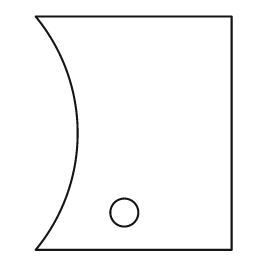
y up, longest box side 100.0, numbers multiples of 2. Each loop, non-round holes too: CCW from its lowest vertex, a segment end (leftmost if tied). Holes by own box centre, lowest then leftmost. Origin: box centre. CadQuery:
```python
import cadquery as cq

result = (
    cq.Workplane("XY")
    .moveTo(-42.0, -50.0)
    .lineTo(42.0, -50.0)
    .lineTo(42.0, 50.0)
    .lineTo(-42.0, 50.0)
    .threePointArc((-24.0, 0.0), (-42.0, -50.0))
    .close()
    .moveTo(-4.0, -34.0)
    .circle(6.0)
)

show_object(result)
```